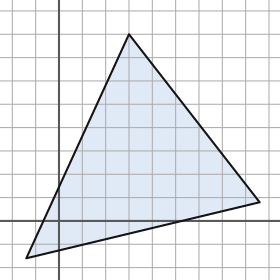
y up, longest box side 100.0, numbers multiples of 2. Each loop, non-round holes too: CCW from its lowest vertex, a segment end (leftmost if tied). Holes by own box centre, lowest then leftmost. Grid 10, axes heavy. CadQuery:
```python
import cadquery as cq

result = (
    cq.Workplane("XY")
    .moveTo(-14.0, -16.0)
    .lineTo(86.0, 8.0)
    .lineTo(30.0, 80.0)
    .close()
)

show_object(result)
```